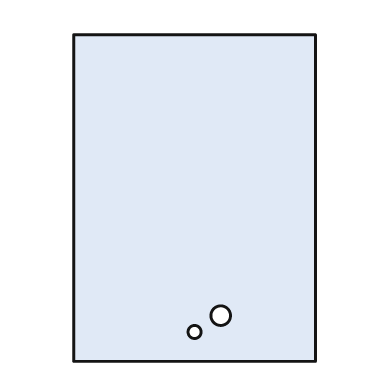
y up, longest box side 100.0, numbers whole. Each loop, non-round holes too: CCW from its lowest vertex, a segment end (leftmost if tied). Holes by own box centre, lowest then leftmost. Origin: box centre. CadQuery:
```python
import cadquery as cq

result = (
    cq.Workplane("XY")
    .moveTo(-37.0, -50.0)
    .lineTo(37.0, -50.0)
    .lineTo(37.0, 50.0)
    .lineTo(-37.0, 50.0)
    .close()
    .moveTo(0.0, -41.0)
    .circle(2.0)
    .moveTo(8.0, -36.0)
    .circle(3.0)
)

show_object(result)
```